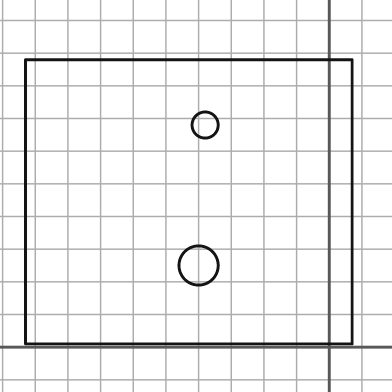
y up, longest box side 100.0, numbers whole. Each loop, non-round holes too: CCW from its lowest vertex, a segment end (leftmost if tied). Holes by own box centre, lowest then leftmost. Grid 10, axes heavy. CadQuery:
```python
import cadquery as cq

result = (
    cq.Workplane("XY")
    .moveTo(-93.0, 1.0)
    .lineTo(7.0, 1.0)
    .lineTo(7.0, 88.0)
    .lineTo(-93.0, 88.0)
    .close()
    .moveTo(-40.0, 25.0)
    .circle(6.0)
    .moveTo(-38.0, 68.0)
    .circle(4.0)
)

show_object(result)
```